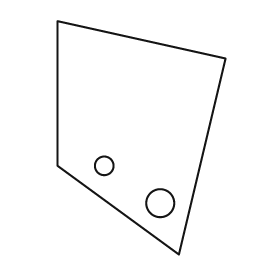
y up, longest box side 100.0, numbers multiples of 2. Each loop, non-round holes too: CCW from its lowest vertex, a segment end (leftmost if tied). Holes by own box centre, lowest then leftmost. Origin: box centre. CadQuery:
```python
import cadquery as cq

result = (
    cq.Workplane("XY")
    .moveTo(16.0, -50.0)
    .lineTo(36.0, 34.0)
    .lineTo(-36.0, 50.0)
    .lineTo(-36.0, -12.0)
    .close()
    .moveTo(8.0, -28.0)
    .circle(6.0)
    .moveTo(-16.0, -12.0)
    .circle(4.0)
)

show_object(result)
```